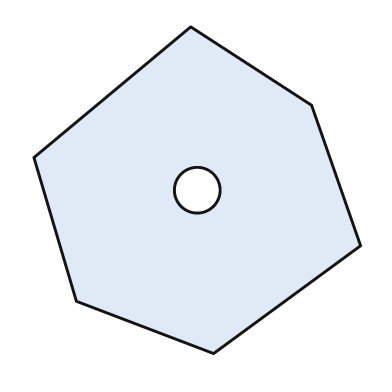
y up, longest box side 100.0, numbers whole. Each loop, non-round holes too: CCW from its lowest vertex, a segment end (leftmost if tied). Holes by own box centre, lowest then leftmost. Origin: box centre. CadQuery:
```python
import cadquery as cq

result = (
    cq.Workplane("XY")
    .moveTo(5.0, -50.0)
    .lineTo(50.0, -17.0)
    .lineTo(35.0, 26.0)
    .lineTo(-2.0, 50.0)
    .lineTo(-50.0, 10.0)
    .lineTo(-37.0, -34.0)
    .close()
    .moveTo(0.0, 0.0)
    .circle(7.0)
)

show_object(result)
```